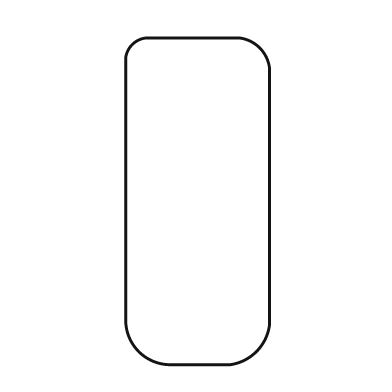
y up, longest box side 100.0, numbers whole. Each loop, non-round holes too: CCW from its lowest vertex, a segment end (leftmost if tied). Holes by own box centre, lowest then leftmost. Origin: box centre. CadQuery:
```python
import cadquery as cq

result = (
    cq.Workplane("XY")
    .moveTo(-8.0, -50.0)
    .lineTo(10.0, -50.0)
    .threePointArc((18.0, -46.0), (22.0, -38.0))
    .lineTo(22.0, 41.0)
    .threePointArc((19.0, 47.0), (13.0, 50.0))
    .lineTo(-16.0, 50.0)
    .threePointArc((-20.0, 48.0), (-22.0, 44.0))
    .lineTo(-22.0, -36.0)
    .threePointArc((-18.0, -46.0), (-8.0, -50.0))
    .close()
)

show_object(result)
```